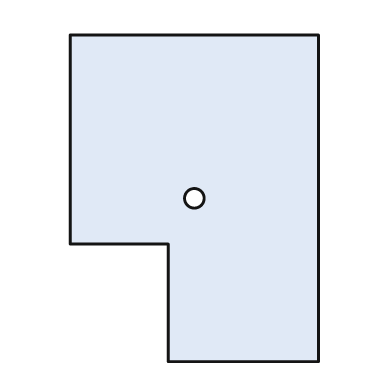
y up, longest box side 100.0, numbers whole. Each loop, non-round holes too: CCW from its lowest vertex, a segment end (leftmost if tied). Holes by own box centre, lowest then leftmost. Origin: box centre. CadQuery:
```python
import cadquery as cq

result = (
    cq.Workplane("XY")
    .moveTo(-8.0, -50.0)
    .lineTo(38.0, -50.0)
    .lineTo(38.0, 50.0)
    .lineTo(-38.0, 50.0)
    .lineTo(-38.0, -14.0)
    .lineTo(-8.0, -14.0)
    .close()
    .moveTo(0.0, 0.0)
    .circle(3.0)
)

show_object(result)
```